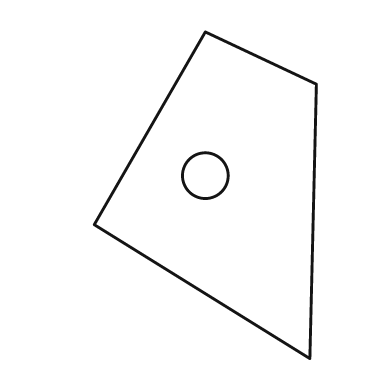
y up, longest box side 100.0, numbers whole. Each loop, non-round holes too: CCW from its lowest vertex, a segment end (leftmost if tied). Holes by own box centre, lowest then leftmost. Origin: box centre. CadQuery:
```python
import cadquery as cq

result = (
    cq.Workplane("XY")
    .moveTo(32.0, -50.0)
    .lineTo(34.0, 34.0)
    .lineTo(0.0, 50.0)
    .lineTo(-34.0, -9.0)
    .close()
    .moveTo(0.0, 6.0)
    .circle(7.0)
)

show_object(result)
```